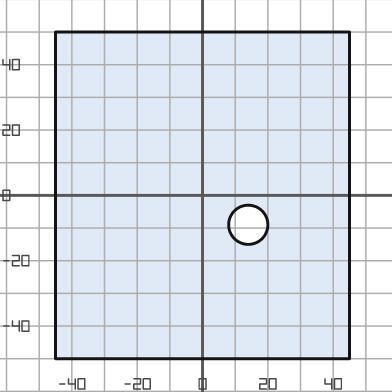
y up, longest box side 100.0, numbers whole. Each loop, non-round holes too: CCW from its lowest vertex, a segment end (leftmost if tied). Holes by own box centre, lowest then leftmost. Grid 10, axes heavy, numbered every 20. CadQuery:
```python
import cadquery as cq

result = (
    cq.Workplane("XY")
    .moveTo(-45.0, -50.0)
    .lineTo(45.0, -50.0)
    .lineTo(45.0, 50.0)
    .lineTo(-45.0, 50.0)
    .close()
    .moveTo(14.0, -9.0)
    .circle(6.0)
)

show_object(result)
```